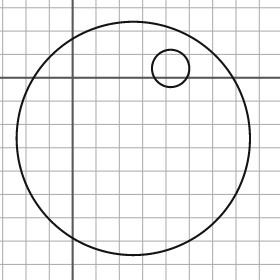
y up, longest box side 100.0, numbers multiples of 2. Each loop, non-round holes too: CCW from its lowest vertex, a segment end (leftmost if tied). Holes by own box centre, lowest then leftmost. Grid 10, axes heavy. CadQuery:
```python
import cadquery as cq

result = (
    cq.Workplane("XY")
    .moveTo(26.0, -26.0)
    .circle(50.0)
    .moveTo(42.0, 4.0)
    .circle(8.0)
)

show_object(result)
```